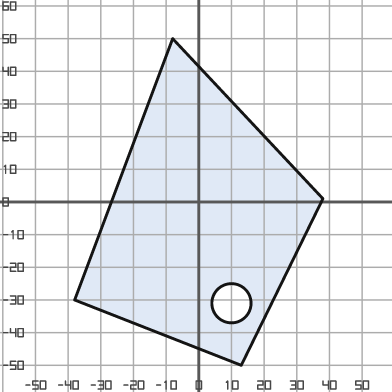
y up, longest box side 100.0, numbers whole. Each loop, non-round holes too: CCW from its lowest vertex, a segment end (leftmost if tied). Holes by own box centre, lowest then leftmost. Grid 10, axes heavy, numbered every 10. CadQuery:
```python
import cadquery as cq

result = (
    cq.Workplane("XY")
    .moveTo(13.0, -50.0)
    .lineTo(38.0, 1.0)
    .lineTo(-8.0, 50.0)
    .lineTo(-38.0, -30.0)
    .close()
    .moveTo(10.0, -31.0)
    .circle(6.0)
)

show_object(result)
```